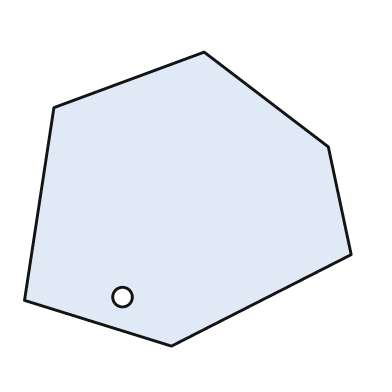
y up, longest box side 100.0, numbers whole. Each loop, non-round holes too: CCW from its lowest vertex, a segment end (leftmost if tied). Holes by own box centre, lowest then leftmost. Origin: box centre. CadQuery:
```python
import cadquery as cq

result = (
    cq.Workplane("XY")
    .moveTo(-5.0, -45.0)
    .lineTo(50.0, -17.0)
    .lineTo(43.0, 16.0)
    .lineTo(5.0, 45.0)
    .lineTo(-41.0, 28.0)
    .lineTo(-50.0, -31.0)
    .close()
    .moveTo(-20.0, -30.0)
    .circle(3.0)
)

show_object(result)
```